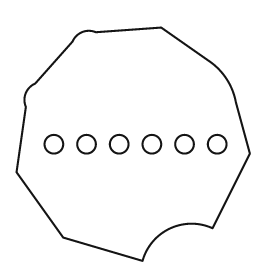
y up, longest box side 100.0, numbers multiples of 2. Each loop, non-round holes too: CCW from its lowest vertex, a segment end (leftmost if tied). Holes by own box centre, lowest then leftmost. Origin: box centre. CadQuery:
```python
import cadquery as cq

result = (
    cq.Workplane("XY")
    .moveTo(4.0, -50.0)
    .threePointArc((16.0, -36.0), (34.0, -36.0))
    .lineTo(50.0, -4.0)
    .lineTo(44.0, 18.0)
    .threePointArc((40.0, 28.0), (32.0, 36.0))
    .lineTo(12.0, 50.0)
    .lineTo(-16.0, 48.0)
    .threePointArc((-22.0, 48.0), (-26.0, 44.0))
    .lineTo(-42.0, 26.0)
    .threePointArc((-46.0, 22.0), (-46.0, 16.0))
    .lineTo(-50.0, -12.0)
    .lineTo(-30.0, -40.0)
    .close()
    .moveTo(-34.0, 0.0)
    .circle(4.0)
    .moveTo(-20.0, 0.0)
    .circle(4.0)
    .moveTo(-6.0, 0.0)
    .circle(4.0)
    .moveTo(8.0, 0.0)
    .circle(4.0)
    .moveTo(22.0, 0.0)
    .circle(4.0)
    .moveTo(36.0, 0.0)
    .circle(4.0)
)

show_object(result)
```